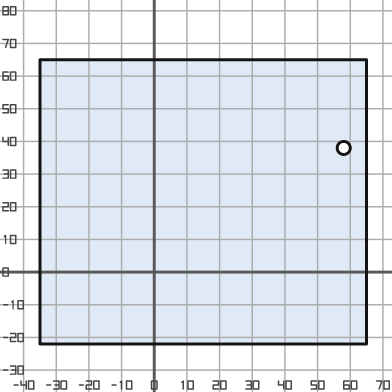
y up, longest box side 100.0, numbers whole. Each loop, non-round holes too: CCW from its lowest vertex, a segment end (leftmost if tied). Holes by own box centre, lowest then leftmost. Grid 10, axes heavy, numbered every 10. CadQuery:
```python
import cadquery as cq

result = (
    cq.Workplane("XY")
    .moveTo(-35.0, -22.0)
    .lineTo(65.0, -22.0)
    .lineTo(65.0, 65.0)
    .lineTo(-35.0, 65.0)
    .close()
    .moveTo(58.0, 38.0)
    .circle(2.0)
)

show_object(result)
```